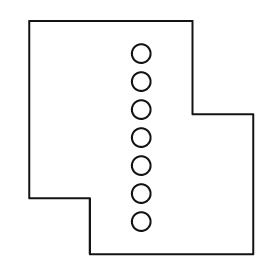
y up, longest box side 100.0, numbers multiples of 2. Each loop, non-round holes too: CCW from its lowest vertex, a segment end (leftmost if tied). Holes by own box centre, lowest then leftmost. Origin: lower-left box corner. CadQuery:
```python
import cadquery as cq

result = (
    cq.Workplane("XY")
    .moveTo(26.0, 0.0)
    .lineTo(96.0, 0.0)
    .lineTo(96.0, 60.0)
    .lineTo(70.0, 60.0)
    .lineTo(70.0, 100.0)
    .lineTo(0.0, 100.0)
    .lineTo(0.0, 24.0)
    .lineTo(26.0, 24.0)
    .close()
    .moveTo(48.0, 14.0)
    .circle(4.0)
    .moveTo(48.0, 26.0)
    .circle(4.0)
    .moveTo(48.0, 38.0)
    .circle(4.0)
    .moveTo(48.0, 50.0)
    .circle(4.0)
    .moveTo(48.0, 62.0)
    .circle(4.0)
    .moveTo(48.0, 74.0)
    .circle(4.0)
    .moveTo(48.0, 86.0)
    .circle(4.0)
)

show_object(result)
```